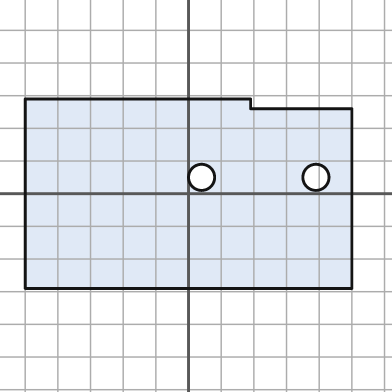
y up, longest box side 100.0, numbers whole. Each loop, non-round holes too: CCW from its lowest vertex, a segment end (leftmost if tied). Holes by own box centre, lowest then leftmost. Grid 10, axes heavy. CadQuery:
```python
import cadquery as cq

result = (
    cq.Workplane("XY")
    .moveTo(-50.0, -29.0)
    .lineTo(50.0, -29.0)
    .lineTo(50.0, 26.0)
    .lineTo(19.0, 26.0)
    .lineTo(19.0, 29.0)
    .lineTo(-50.0, 29.0)
    .close()
    .moveTo(4.0, 5.0)
    .circle(4.0)
    .moveTo(39.0, 5.0)
    .circle(4.0)
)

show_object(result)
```